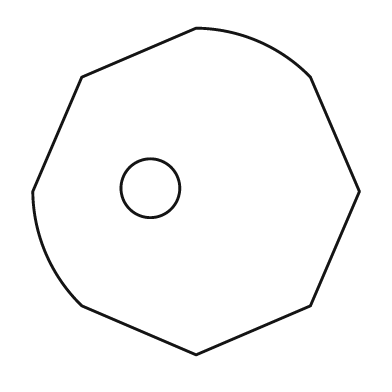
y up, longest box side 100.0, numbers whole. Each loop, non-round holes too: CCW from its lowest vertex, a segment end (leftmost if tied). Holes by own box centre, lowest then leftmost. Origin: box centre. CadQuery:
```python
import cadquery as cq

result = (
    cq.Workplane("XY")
    .moveTo(0.0, -50.0)
    .lineTo(35.0, -35.0)
    .lineTo(50.0, 0.0)
    .lineTo(35.0, 35.0)
    .threePointArc((19.0, 46.0), (0.0, 50.0))
    .lineTo(-35.0, 35.0)
    .lineTo(-50.0, 0.0)
    .threePointArc((-46.0, -19.0), (-35.0, -35.0))
    .close()
    .moveTo(-14.0, 1.0)
    .circle(9.0)
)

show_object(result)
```